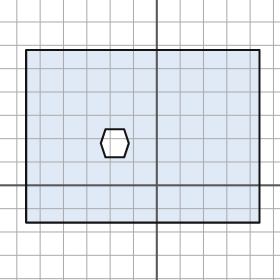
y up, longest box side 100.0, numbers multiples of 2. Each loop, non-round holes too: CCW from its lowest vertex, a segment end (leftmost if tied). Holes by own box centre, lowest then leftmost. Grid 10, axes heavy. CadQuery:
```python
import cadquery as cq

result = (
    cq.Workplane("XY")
    .moveTo(-56.0, -16.0)
    .lineTo(44.0, -16.0)
    .lineTo(44.0, 58.0)
    .lineTo(-56.0, 58.0)
    .close()
    .moveTo(-22.0, 12.0)
    .lineTo(-14.0, 12.0)
    .lineTo(-12.0, 18.0)
    .lineTo(-14.0, 24.0)
    .lineTo(-22.0, 24.0)
    .lineTo(-24.0, 18.0)
    .close()
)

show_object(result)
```